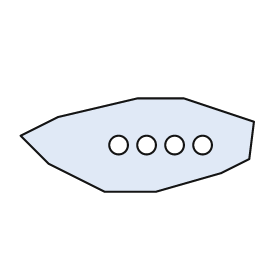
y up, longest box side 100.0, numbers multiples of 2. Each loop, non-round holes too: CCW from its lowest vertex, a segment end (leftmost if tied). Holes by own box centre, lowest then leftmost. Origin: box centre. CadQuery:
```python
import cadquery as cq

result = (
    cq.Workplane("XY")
    .moveTo(-14.0, -20.0)
    .lineTo(8.0, -20.0)
    .lineTo(36.0, -12.0)
    .lineTo(48.0, -6.0)
    .lineTo(50.0, 10.0)
    .lineTo(20.0, 20.0)
    .lineTo(0.0, 20.0)
    .lineTo(-34.0, 12.0)
    .lineTo(-50.0, 4.0)
    .lineTo(-38.0, -8.0)
    .close()
    .moveTo(-8.0, 0.0)
    .circle(4.0)
    .moveTo(4.0, 0.0)
    .circle(4.0)
    .moveTo(16.0, 0.0)
    .circle(4.0)
    .moveTo(28.0, 0.0)
    .circle(4.0)
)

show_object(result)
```